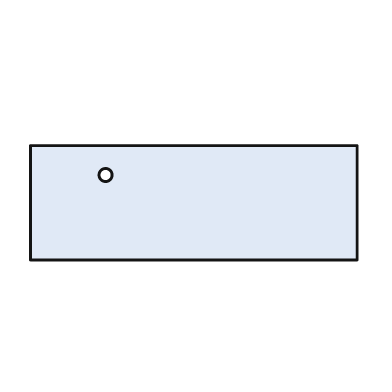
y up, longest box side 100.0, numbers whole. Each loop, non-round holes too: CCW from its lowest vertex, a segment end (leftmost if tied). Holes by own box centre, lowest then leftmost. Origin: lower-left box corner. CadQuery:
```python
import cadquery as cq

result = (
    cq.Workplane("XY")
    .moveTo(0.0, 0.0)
    .lineTo(100.0, 0.0)
    .lineTo(100.0, 35.0)
    .lineTo(0.0, 35.0)
    .close()
    .moveTo(23.0, 26.0)
    .circle(2.0)
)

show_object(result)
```